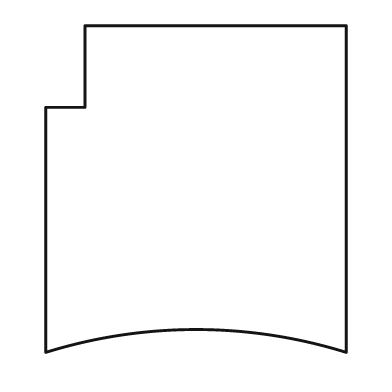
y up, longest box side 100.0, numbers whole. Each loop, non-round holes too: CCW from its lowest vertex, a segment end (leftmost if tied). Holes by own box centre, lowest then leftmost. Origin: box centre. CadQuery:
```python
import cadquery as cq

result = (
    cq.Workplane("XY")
    .moveTo(-46.0, -50.0)
    .threePointArc((0.0, -43.0), (46.0, -50.0))
    .lineTo(46.0, 50.0)
    .lineTo(-34.0, 50.0)
    .lineTo(-34.0, 25.0)
    .lineTo(-46.0, 25.0)
    .close()
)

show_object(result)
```